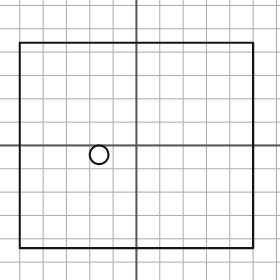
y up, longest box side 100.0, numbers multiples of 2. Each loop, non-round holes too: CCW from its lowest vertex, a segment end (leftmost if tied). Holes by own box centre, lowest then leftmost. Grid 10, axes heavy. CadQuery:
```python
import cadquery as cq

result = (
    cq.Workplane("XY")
    .moveTo(-50.0, -44.0)
    .lineTo(50.0, -44.0)
    .lineTo(50.0, 44.0)
    .lineTo(-50.0, 44.0)
    .close()
    .moveTo(-16.0, -4.0)
    .circle(4.0)
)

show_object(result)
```